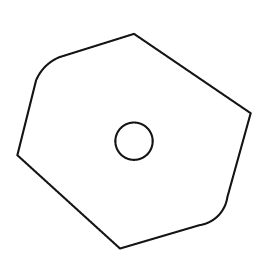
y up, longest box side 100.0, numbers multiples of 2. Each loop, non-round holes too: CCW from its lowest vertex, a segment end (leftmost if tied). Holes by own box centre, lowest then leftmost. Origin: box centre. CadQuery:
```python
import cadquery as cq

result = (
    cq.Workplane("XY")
    .moveTo(-6.0, -46.0)
    .lineTo(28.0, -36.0)
    .threePointArc((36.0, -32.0), (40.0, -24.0))
    .lineTo(50.0, 12.0)
    .lineTo(0.0, 46.0)
    .lineTo(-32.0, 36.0)
    .threePointArc((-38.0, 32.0), (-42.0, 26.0))
    .lineTo(-50.0, -6.0)
    .close()
    .moveTo(0.0, 0.0)
    .circle(8.0)
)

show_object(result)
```